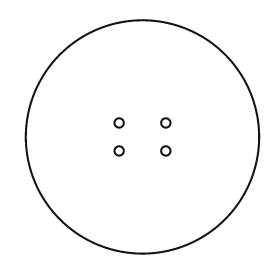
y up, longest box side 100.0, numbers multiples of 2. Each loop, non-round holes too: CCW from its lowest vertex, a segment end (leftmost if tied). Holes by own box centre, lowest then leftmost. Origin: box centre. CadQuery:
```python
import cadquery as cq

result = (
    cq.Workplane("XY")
    .moveTo(0.0, 0.0)
    .circle(50.0)
    .moveTo(-10.0, -6.0)
    .circle(2.0)
    .moveTo(10.0, -6.0)
    .circle(2.0)
    .moveTo(-10.0, 6.0)
    .circle(2.0)
    .moveTo(10.0, 6.0)
    .circle(2.0)
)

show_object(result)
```